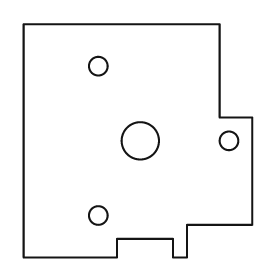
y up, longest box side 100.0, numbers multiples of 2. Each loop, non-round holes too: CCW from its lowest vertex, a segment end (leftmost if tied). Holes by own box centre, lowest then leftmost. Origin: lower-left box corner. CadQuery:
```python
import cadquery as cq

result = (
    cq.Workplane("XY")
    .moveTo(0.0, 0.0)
    .lineTo(40.0, 0.0)
    .lineTo(40.0, 8.0)
    .lineTo(64.0, 8.0)
    .lineTo(64.0, 0.0)
    .lineTo(70.0, 0.0)
    .lineTo(70.0, 14.0)
    .lineTo(98.0, 14.0)
    .lineTo(98.0, 60.0)
    .lineTo(84.0, 60.0)
    .lineTo(84.0, 100.0)
    .lineTo(0.0, 100.0)
    .close()
    .moveTo(32.0, 18.0)
    .circle(4.0)
    .moveTo(50.0, 50.0)
    .circle(8.0)
    .moveTo(88.0, 50.0)
    .circle(4.0)
    .moveTo(32.0, 82.0)
    .circle(4.0)
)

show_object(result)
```